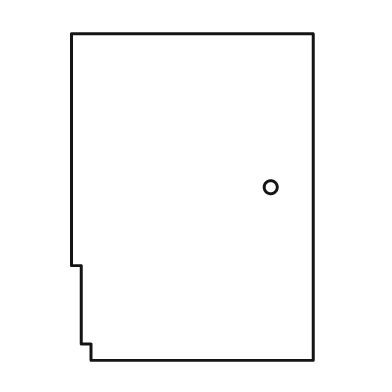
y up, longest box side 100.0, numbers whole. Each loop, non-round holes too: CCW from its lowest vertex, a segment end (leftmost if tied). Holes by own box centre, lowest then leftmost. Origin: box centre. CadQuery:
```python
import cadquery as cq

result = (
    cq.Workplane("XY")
    .moveTo(-31.0, -50.0)
    .lineTo(37.0, -50.0)
    .lineTo(37.0, 50.0)
    .lineTo(-37.0, 50.0)
    .lineTo(-37.0, -21.0)
    .lineTo(-34.0, -21.0)
    .lineTo(-34.0, -45.0)
    .lineTo(-31.0, -45.0)
    .close()
    .moveTo(24.0, 3.0)
    .circle(2.0)
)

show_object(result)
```